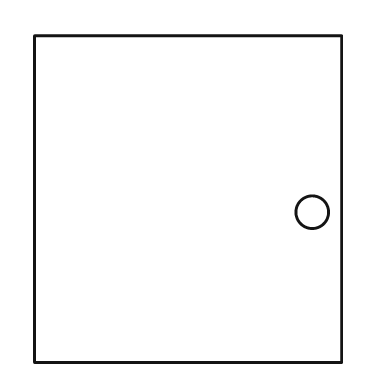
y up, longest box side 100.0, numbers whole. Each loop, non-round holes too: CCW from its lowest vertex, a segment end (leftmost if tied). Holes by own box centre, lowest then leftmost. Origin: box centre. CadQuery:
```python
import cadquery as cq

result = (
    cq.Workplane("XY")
    .moveTo(-47.0, -50.0)
    .lineTo(47.0, -50.0)
    .lineTo(47.0, 50.0)
    .lineTo(-47.0, 50.0)
    .close()
    .moveTo(38.0, -4.0)
    .circle(5.0)
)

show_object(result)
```